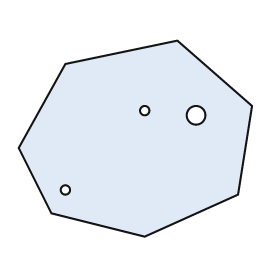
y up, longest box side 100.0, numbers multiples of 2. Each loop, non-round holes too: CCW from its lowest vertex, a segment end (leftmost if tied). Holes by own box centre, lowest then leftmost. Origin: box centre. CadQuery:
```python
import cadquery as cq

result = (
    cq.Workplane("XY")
    .moveTo(4.0, -42.0)
    .lineTo(44.0, -24.0)
    .lineTo(50.0, 14.0)
    .lineTo(18.0, 42.0)
    .lineTo(-30.0, 32.0)
    .lineTo(-50.0, -4.0)
    .lineTo(-36.0, -32.0)
    .close()
    .moveTo(-30.0, -22.0)
    .circle(2.0)
    .moveTo(26.0, 10.0)
    .circle(4.0)
    .moveTo(4.0, 12.0)
    .circle(2.0)
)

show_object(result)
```